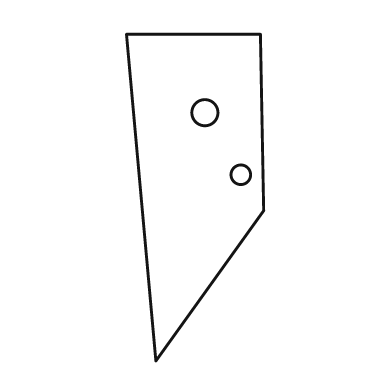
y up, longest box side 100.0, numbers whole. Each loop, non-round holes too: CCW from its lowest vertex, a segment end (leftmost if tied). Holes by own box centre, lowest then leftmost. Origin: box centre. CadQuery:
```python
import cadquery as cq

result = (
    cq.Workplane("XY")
    .moveTo(-12.0, -50.0)
    .lineTo(21.0, -4.0)
    .lineTo(20.0, 50.0)
    .lineTo(-21.0, 50.0)
    .close()
    .moveTo(14.0, 7.0)
    .circle(3.0)
    .moveTo(3.0, 26.0)
    .circle(4.0)
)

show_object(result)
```